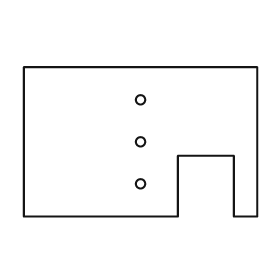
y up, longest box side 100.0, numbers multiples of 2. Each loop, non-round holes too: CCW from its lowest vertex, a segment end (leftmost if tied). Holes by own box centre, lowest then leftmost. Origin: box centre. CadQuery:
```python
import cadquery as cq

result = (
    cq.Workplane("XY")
    .moveTo(-50.0, -32.0)
    .lineTo(16.0, -32.0)
    .lineTo(16.0, -6.0)
    .lineTo(40.0, -6.0)
    .lineTo(40.0, -32.0)
    .lineTo(50.0, -32.0)
    .lineTo(50.0, 32.0)
    .lineTo(-50.0, 32.0)
    .close()
    .moveTo(0.0, -18.0)
    .circle(2.0)
    .moveTo(0.0, 0.0)
    .circle(2.0)
    .moveTo(0.0, 18.0)
    .circle(2.0)
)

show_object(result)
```